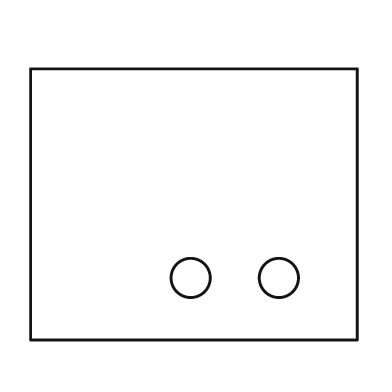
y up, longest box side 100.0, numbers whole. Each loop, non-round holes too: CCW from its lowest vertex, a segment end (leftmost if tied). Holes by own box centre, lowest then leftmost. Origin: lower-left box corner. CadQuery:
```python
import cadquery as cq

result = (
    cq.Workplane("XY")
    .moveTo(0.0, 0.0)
    .lineTo(100.0, 0.0)
    .lineTo(100.0, 83.0)
    .lineTo(0.0, 83.0)
    .close()
    .moveTo(49.0, 19.0)
    .circle(6.0)
    .moveTo(76.0, 19.0)
    .circle(6.0)
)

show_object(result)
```